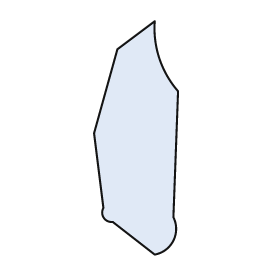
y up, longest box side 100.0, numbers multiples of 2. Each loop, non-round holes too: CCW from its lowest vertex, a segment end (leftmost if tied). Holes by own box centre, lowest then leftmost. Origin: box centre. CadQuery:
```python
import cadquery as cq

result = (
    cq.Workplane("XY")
    .moveTo(8.0, -50.0)
    .threePointArc((16.0, -44.0), (16.0, -34.0))
    .lineTo(18.0, 20.0)
    .threePointArc((10.0, 34.0), (8.0, 50.0))
    .lineTo(-8.0, 38.0)
    .lineTo(-18.0, 2.0)
    .lineTo(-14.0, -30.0)
    .threePointArc((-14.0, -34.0), (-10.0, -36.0))
    .close()
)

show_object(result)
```